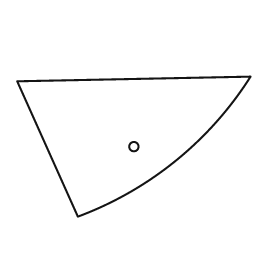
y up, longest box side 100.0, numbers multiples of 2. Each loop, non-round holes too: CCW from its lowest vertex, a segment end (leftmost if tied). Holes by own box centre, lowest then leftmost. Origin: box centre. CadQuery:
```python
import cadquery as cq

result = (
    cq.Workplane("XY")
    .moveTo(-24.0, -30.0)
    .threePointArc((18.0, -6.0), (50.0, 30.0))
    .lineTo(-50.0, 28.0)
    .close()
    .moveTo(0.0, 0.0)
    .circle(2.0)
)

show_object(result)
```